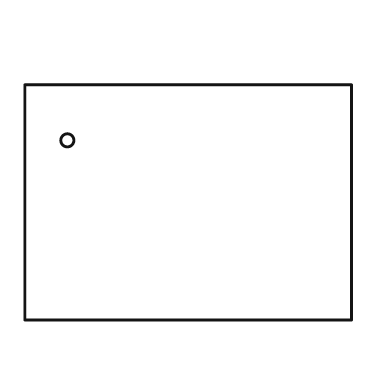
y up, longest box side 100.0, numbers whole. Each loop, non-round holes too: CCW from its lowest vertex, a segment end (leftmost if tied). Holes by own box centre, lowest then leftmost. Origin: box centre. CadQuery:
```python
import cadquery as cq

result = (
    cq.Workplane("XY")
    .moveTo(-50.0, -36.0)
    .lineTo(50.0, -36.0)
    .lineTo(50.0, 36.0)
    .lineTo(-50.0, 36.0)
    .close()
    .moveTo(-37.0, 19.0)
    .circle(2.0)
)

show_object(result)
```